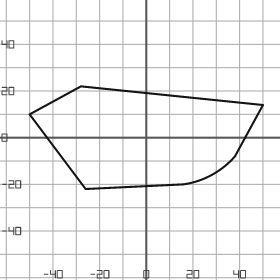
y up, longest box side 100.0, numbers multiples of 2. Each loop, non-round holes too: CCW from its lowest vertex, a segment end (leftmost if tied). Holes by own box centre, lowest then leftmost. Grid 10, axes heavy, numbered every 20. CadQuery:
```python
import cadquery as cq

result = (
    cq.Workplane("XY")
    .moveTo(-26.0, -22.0)
    .lineTo(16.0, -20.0)
    .threePointArc((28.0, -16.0), (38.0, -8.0))
    .lineTo(50.0, 14.0)
    .lineTo(-28.0, 22.0)
    .lineTo(-50.0, 10.0)
    .close()
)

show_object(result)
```